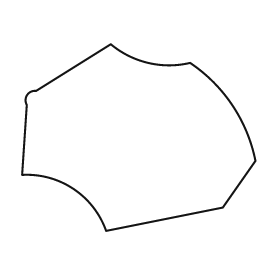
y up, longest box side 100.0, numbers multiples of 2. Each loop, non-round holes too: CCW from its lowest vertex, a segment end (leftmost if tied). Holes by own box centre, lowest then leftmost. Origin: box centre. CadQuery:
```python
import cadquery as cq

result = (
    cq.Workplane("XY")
    .moveTo(-14.0, -40.0)
    .lineTo(36.0, -30.0)
    .lineTo(50.0, -10.0)
    .threePointArc((40.0, 14.0), (22.0, 32.0))
    .threePointArc((4.0, 32.0), (-12.0, 40.0))
    .lineTo(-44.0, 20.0)
    .threePointArc((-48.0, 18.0), (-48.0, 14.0))
    .lineTo(-50.0, -16.0)
    .threePointArc((-28.0, -22.0), (-14.0, -40.0))
    .close()
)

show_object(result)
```